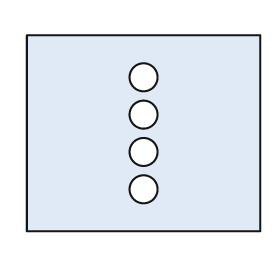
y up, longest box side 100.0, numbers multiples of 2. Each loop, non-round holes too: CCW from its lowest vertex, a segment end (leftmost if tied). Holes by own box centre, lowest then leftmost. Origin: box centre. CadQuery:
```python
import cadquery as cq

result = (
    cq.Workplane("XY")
    .moveTo(-50.0, -42.0)
    .lineTo(50.0, -42.0)
    .lineTo(50.0, 42.0)
    .lineTo(-50.0, 42.0)
    .close()
    .moveTo(0.0, -24.0)
    .circle(6.0)
    .moveTo(0.0, -8.0)
    .circle(6.0)
    .moveTo(0.0, 8.0)
    .circle(6.0)
    .moveTo(0.0, 24.0)
    .circle(6.0)
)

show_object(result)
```